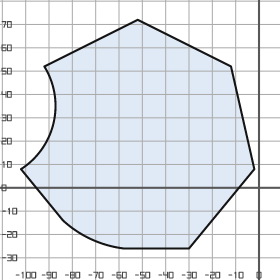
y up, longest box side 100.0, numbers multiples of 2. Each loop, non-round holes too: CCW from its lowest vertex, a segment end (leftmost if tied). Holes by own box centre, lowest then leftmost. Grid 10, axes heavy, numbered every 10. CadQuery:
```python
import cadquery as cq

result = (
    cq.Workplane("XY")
    .moveTo(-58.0, -26.0)
    .lineTo(-30.0, -26.0)
    .lineTo(-2.0, 8.0)
    .lineTo(-12.0, 52.0)
    .lineTo(-52.0, 72.0)
    .lineTo(-92.0, 52.0)
    .threePointArc((-88.0, 28.0), (-102.0, 8.0))
    .lineTo(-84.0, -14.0)
    .threePointArc((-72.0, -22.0), (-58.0, -26.0))
    .close()
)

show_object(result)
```